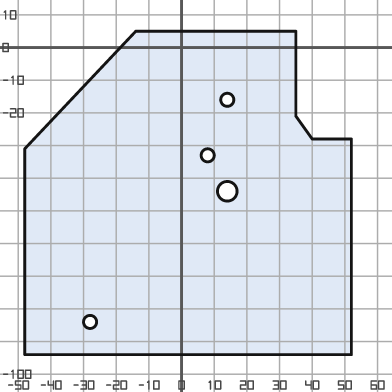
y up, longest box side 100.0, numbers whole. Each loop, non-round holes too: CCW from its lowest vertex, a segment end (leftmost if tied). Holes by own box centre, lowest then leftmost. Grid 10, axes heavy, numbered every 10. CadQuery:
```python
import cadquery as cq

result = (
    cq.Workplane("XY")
    .moveTo(-48.0, -94.0)
    .lineTo(52.0, -94.0)
    .lineTo(52.0, -28.0)
    .lineTo(40.0, -28.0)
    .lineTo(35.0, -21.0)
    .lineTo(35.0, 5.0)
    .lineTo(-14.0, 5.0)
    .lineTo(-48.0, -31.0)
    .close()
    .moveTo(-28.0, -84.0)
    .circle(2.0)
    .moveTo(14.0, -44.0)
    .circle(3.0)
    .moveTo(8.0, -33.0)
    .circle(2.0)
    .moveTo(14.0, -16.0)
    .circle(2.0)
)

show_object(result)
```